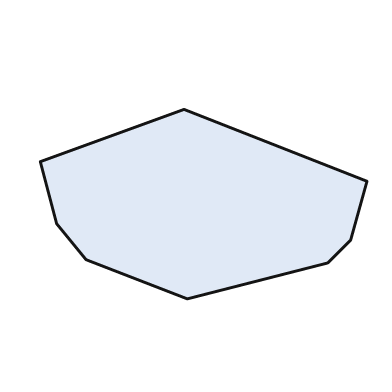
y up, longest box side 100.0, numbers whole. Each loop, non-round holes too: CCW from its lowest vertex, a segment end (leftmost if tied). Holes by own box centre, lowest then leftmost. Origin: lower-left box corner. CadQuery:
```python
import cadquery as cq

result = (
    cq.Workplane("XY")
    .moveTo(45.0, 0.0)
    .lineTo(88.0, 11.0)
    .lineTo(95.0, 18.0)
    .lineTo(100.0, 36.0)
    .lineTo(44.0, 58.0)
    .lineTo(0.0, 42.0)
    .lineTo(5.0, 23.0)
    .lineTo(14.0, 12.0)
    .close()
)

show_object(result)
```